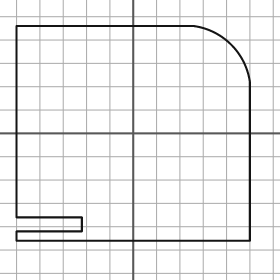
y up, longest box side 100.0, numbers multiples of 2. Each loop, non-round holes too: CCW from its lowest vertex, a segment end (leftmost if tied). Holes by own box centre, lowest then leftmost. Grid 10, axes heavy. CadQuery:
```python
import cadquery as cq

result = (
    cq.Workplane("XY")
    .moveTo(-50.0, -46.0)
    .lineTo(50.0, -46.0)
    .lineTo(50.0, 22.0)
    .threePointArc((42.0, 38.0), (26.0, 46.0))
    .lineTo(-50.0, 46.0)
    .lineTo(-50.0, -36.0)
    .lineTo(-22.0, -36.0)
    .lineTo(-22.0, -42.0)
    .lineTo(-50.0, -42.0)
    .close()
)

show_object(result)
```